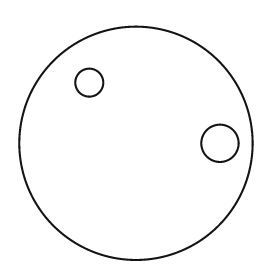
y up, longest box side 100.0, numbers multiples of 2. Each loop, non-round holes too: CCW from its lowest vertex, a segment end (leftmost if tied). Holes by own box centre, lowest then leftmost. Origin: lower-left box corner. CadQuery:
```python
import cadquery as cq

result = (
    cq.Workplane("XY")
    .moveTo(50.0, 50.0)
    .circle(50.0)
    .moveTo(86.0, 50.0)
    .circle(8.0)
    .moveTo(30.0, 76.0)
    .circle(6.0)
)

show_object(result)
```